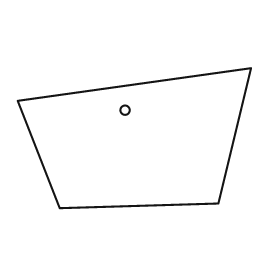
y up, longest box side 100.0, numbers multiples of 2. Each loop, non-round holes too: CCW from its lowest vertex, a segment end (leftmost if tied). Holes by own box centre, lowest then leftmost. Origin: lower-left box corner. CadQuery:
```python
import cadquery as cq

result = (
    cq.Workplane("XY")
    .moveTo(18.0, 0.0)
    .lineTo(86.0, 2.0)
    .lineTo(100.0, 60.0)
    .lineTo(0.0, 46.0)
    .close()
    .moveTo(46.0, 42.0)
    .circle(2.0)
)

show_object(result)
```